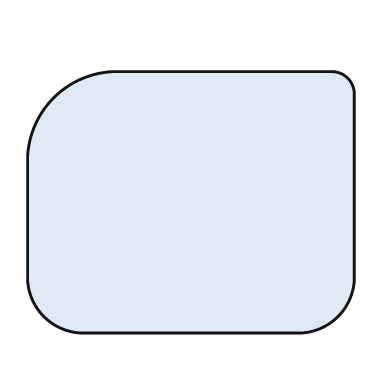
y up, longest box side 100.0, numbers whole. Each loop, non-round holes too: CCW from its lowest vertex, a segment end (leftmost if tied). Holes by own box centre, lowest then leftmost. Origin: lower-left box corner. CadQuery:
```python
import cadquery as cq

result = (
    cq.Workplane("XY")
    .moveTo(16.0, 0.0)
    .lineTo(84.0, 0.0)
    .threePointArc((95.0, 5.0), (100.0, 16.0))
    .lineTo(100.0, 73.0)
    .threePointArc((98.0, 78.0), (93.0, 80.0))
    .lineTo(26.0, 80.0)
    .threePointArc((8.0, 72.0), (0.0, 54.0))
    .lineTo(0.0, 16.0)
    .threePointArc((5.0, 5.0), (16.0, 0.0))
    .close()
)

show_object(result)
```